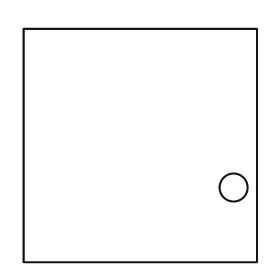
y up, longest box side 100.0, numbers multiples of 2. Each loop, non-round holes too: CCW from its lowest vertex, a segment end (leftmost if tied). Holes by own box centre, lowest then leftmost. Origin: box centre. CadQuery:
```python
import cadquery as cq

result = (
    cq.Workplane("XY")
    .moveTo(-50.0, -50.0)
    .lineTo(50.0, -50.0)
    .lineTo(50.0, 50.0)
    .lineTo(-50.0, 50.0)
    .close()
    .moveTo(40.0, -18.0)
    .circle(6.0)
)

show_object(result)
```